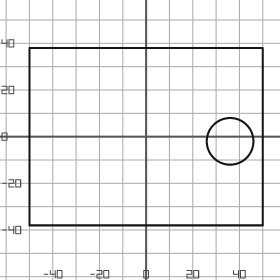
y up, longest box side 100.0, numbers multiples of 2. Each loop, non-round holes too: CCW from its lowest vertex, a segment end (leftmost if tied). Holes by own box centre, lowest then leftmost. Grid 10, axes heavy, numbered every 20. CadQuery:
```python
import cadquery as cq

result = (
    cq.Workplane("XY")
    .moveTo(-50.0, -38.0)
    .lineTo(50.0, -38.0)
    .lineTo(50.0, 38.0)
    .lineTo(-50.0, 38.0)
    .close()
    .moveTo(36.0, -2.0)
    .circle(10.0)
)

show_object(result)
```